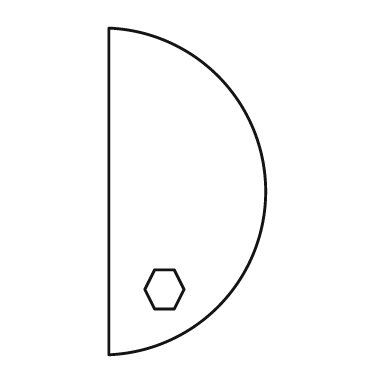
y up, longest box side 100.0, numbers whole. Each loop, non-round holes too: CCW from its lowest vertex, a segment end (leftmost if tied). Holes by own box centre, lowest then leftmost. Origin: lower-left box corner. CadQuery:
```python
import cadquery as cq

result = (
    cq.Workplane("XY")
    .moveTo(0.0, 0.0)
    .threePointArc((48.0, 50.0), (0.0, 100.0))
    .close()
    .moveTo(14.0, 14.0)
    .lineTo(20.0, 14.0)
    .lineTo(23.0, 20.0)
    .lineTo(20.0, 26.0)
    .lineTo(14.0, 26.0)
    .lineTo(11.0, 20.0)
    .close()
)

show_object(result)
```